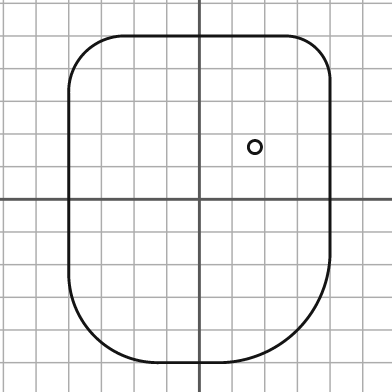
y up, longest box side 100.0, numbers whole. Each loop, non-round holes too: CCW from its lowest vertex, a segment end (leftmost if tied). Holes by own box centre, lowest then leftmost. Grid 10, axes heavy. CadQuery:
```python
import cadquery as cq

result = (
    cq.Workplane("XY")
    .moveTo(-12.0, -50.0)
    .lineTo(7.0, -50.0)
    .threePointArc((30.0, -40.0), (40.0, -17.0))
    .lineTo(40.0, 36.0)
    .threePointArc((36.0, 46.0), (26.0, 50.0))
    .lineTo(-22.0, 50.0)
    .threePointArc((-35.0, 45.0), (-40.0, 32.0))
    .lineTo(-40.0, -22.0)
    .threePointArc((-32.0, -42.0), (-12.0, -50.0))
    .close()
    .moveTo(17.0, 16.0)
    .circle(2.0)
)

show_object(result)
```